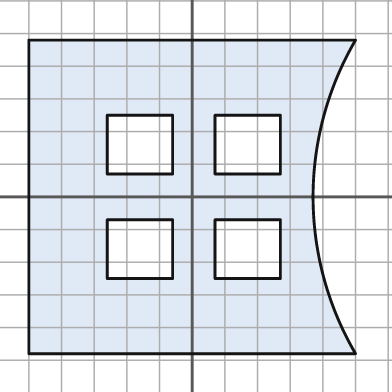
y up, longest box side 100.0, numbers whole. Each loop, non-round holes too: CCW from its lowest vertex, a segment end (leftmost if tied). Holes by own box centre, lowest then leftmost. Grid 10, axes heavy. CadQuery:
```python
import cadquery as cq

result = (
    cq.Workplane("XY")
    .moveTo(-50.0, -48.0)
    .lineTo(50.0, -48.0)
    .threePointArc((37.0, 0.0), (50.0, 48.0))
    .lineTo(-50.0, 48.0)
    .close()
    .moveTo(-26.0, -25.0)
    .lineTo(-6.0, -25.0)
    .lineTo(-6.0, -7.0)
    .lineTo(-26.0, -7.0)
    .close()
    .moveTo(7.0, -25.0)
    .lineTo(27.0, -25.0)
    .lineTo(27.0, -7.0)
    .lineTo(7.0, -7.0)
    .close()
    .moveTo(-26.0, 7.0)
    .lineTo(-6.0, 7.0)
    .lineTo(-6.0, 25.0)
    .lineTo(-26.0, 25.0)
    .close()
    .moveTo(7.0, 7.0)
    .lineTo(27.0, 7.0)
    .lineTo(27.0, 25.0)
    .lineTo(7.0, 25.0)
    .close()
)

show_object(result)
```